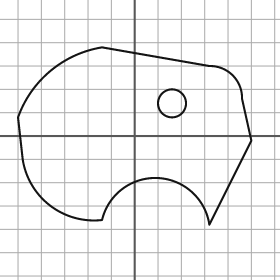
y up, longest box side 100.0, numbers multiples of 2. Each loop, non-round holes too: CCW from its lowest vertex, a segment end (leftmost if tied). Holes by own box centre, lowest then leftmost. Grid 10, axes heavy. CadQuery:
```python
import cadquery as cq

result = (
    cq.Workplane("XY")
    .moveTo(32.0, -38.0)
    .lineTo(50.0, -2.0)
    .lineTo(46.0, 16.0)
    .threePointArc((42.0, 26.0), (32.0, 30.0))
    .lineTo(-14.0, 38.0)
    .threePointArc((-36.0, 28.0), (-50.0, 8.0))
    .lineTo(-48.0, -10.0)
    .threePointArc((-36.0, -30.0), (-14.0, -36.0))
    .threePointArc((10.0, -18.0), (32.0, -38.0))
    .close()
    .moveTo(16.0, 14.0)
    .circle(6.0)
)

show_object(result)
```